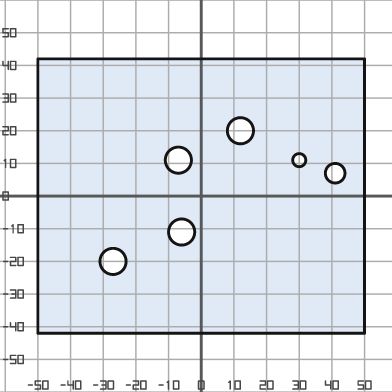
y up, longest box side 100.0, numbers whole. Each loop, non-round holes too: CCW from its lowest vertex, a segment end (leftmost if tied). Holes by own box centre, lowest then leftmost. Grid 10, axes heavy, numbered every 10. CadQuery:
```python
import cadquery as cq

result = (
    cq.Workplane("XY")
    .moveTo(-50.0, -42.0)
    .lineTo(50.0, -42.0)
    .lineTo(50.0, 42.0)
    .lineTo(-50.0, 42.0)
    .close()
    .moveTo(-27.0, -20.0)
    .circle(4.0)
    .moveTo(-6.0, -11.0)
    .circle(4.0)
    .moveTo(41.0, 7.0)
    .circle(3.0)
    .moveTo(-7.0, 11.0)
    .circle(4.0)
    .moveTo(30.0, 11.0)
    .circle(2.0)
    .moveTo(12.0, 20.0)
    .circle(4.0)
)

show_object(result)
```